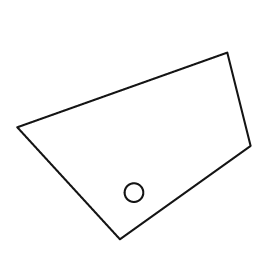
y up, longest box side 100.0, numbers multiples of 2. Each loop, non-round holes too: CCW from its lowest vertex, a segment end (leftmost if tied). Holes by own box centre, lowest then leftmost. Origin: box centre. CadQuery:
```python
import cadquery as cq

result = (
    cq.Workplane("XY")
    .moveTo(-6.0, -40.0)
    .lineTo(50.0, 0.0)
    .lineTo(40.0, 40.0)
    .lineTo(-50.0, 8.0)
    .close()
    .moveTo(0.0, -20.0)
    .circle(4.0)
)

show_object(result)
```